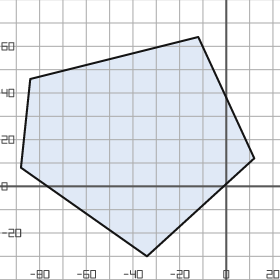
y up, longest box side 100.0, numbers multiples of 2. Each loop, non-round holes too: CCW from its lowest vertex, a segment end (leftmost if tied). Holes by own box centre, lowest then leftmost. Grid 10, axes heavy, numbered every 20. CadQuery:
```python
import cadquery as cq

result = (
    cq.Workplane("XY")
    .moveTo(-34.0, -30.0)
    .lineTo(12.0, 12.0)
    .lineTo(-12.0, 64.0)
    .lineTo(-84.0, 46.0)
    .lineTo(-88.0, 8.0)
    .close()
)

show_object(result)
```